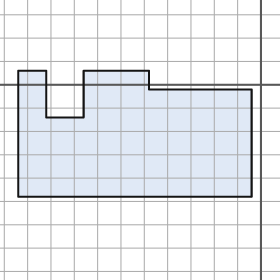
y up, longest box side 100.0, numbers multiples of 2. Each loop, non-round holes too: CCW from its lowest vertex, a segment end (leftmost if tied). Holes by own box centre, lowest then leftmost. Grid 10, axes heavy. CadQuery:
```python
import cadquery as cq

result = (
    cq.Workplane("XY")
    .moveTo(-104.0, -48.0)
    .lineTo(-4.0, -48.0)
    .lineTo(-4.0, -2.0)
    .lineTo(-48.0, -2.0)
    .lineTo(-48.0, 6.0)
    .lineTo(-76.0, 6.0)
    .lineTo(-76.0, -14.0)
    .lineTo(-92.0, -14.0)
    .lineTo(-92.0, 6.0)
    .lineTo(-104.0, 6.0)
    .close()
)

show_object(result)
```